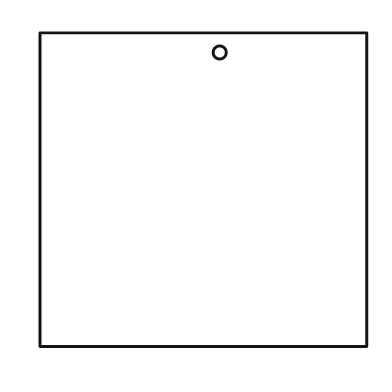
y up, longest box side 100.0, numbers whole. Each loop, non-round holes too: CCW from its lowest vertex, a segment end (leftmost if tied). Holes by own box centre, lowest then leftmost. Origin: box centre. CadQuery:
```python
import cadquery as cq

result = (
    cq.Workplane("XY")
    .moveTo(-50.0, -48.0)
    .lineTo(50.0, -48.0)
    .lineTo(50.0, 48.0)
    .lineTo(-50.0, 48.0)
    .close()
    .moveTo(5.0, 42.0)
    .circle(2.0)
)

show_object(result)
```